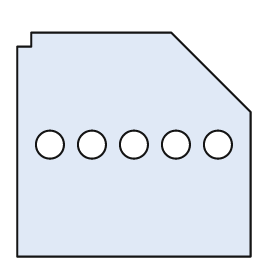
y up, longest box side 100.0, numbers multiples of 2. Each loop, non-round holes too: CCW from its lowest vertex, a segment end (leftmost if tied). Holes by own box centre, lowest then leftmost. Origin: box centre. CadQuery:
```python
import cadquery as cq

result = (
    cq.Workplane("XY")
    .moveTo(-50.0, -48.0)
    .lineTo(50.0, -48.0)
    .lineTo(50.0, 14.0)
    .lineTo(16.0, 48.0)
    .lineTo(-44.0, 48.0)
    .lineTo(-44.0, 42.0)
    .lineTo(-50.0, 42.0)
    .close()
    .moveTo(-36.0, 0.0)
    .circle(6.0)
    .moveTo(-18.0, 0.0)
    .circle(6.0)
    .moveTo(0.0, 0.0)
    .circle(6.0)
    .moveTo(18.0, 0.0)
    .circle(6.0)
    .moveTo(36.0, 0.0)
    .circle(6.0)
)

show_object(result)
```